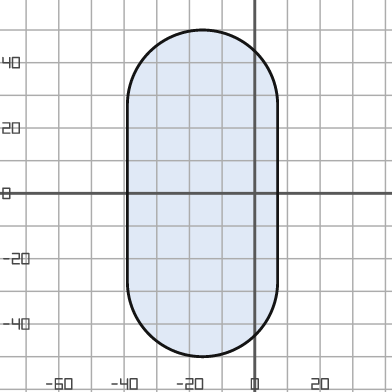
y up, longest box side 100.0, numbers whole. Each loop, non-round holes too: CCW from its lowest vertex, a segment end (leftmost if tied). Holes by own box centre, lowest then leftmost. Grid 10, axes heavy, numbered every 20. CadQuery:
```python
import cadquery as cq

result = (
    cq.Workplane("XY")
    .moveTo(-39.0, -27.0)
    .threePointArc((-16.0, -50.0), (7.0, -27.0))
    .lineTo(7.0, 27.0)
    .threePointArc((-16.0, 50.0), (-39.0, 27.0))
    .close()
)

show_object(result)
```